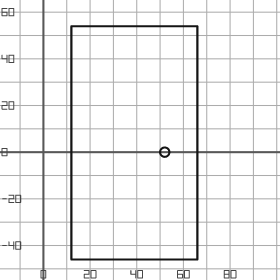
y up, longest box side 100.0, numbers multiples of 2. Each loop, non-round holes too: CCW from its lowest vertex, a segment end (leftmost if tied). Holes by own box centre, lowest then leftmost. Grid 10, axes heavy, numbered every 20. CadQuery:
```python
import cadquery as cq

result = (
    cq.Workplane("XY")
    .moveTo(12.0, -46.0)
    .lineTo(66.0, -46.0)
    .lineTo(66.0, 54.0)
    .lineTo(12.0, 54.0)
    .close()
    .moveTo(52.0, 0.0)
    .circle(2.0)
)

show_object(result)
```